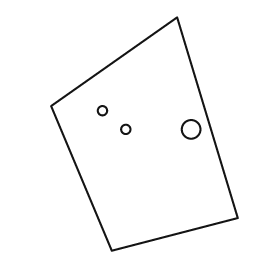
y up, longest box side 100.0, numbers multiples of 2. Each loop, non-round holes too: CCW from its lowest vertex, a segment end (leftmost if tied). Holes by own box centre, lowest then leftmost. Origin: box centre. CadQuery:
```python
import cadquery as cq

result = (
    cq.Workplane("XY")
    .moveTo(-14.0, -50.0)
    .lineTo(40.0, -36.0)
    .lineTo(14.0, 50.0)
    .lineTo(-40.0, 12.0)
    .close()
    .moveTo(-8.0, 2.0)
    .circle(2.0)
    .moveTo(20.0, 2.0)
    .circle(4.0)
    .moveTo(-18.0, 10.0)
    .circle(2.0)
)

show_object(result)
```